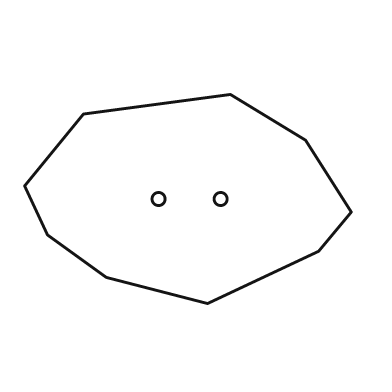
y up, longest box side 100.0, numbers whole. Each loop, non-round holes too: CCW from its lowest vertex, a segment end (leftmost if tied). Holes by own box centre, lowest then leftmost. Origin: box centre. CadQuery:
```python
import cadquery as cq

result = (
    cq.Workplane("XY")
    .moveTo(6.0, -32.0)
    .lineTo(40.0, -16.0)
    .lineTo(50.0, -4.0)
    .lineTo(36.0, 18.0)
    .lineTo(13.0, 32.0)
    .lineTo(-32.0, 26.0)
    .lineTo(-50.0, 4.0)
    .lineTo(-43.0, -11.0)
    .lineTo(-25.0, -24.0)
    .close()
    .moveTo(-9.0, 0.0)
    .circle(2.0)
    .moveTo(10.0, 0.0)
    .circle(2.0)
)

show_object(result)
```